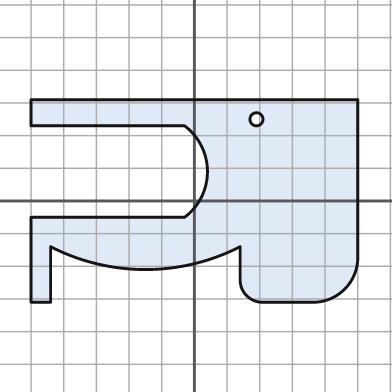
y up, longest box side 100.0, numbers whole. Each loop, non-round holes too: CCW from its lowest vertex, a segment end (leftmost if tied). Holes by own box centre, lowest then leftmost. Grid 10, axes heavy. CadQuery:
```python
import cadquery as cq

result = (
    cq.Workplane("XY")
    .moveTo(-50.0, -31.0)
    .lineTo(-44.0, -31.0)
    .lineTo(-44.0, -14.0)
    .threePointArc((-15.0, -21.0), (14.0, -14.0))
    .lineTo(14.0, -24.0)
    .threePointArc((16.0, -29.0), (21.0, -31.0))
    .lineTo(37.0, -31.0)
    .threePointArc((46.0, -27.0), (50.0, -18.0))
    .lineTo(50.0, 31.0)
    .lineTo(-50.0, 31.0)
    .lineTo(-50.0, 23.0)
    .lineTo(-3.0, 23.0)
    .threePointArc((4.0, 9.0), (-3.0, -5.0))
    .lineTo(-50.0, -5.0)
    .close()
    .moveTo(19.0, 25.0)
    .circle(2.0)
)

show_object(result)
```